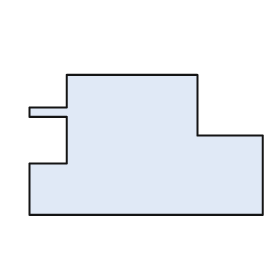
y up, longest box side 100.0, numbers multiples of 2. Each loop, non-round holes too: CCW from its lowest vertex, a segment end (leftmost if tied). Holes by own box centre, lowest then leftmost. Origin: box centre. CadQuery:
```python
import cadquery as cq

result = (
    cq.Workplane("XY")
    .moveTo(-50.0, -30.0)
    .lineTo(50.0, -30.0)
    .lineTo(50.0, 4.0)
    .lineTo(22.0, 4.0)
    .lineTo(22.0, 30.0)
    .lineTo(-34.0, 30.0)
    .lineTo(-34.0, 16.0)
    .lineTo(-50.0, 16.0)
    .lineTo(-50.0, 12.0)
    .lineTo(-34.0, 12.0)
    .lineTo(-34.0, -8.0)
    .lineTo(-50.0, -8.0)
    .close()
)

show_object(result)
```